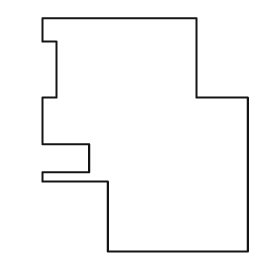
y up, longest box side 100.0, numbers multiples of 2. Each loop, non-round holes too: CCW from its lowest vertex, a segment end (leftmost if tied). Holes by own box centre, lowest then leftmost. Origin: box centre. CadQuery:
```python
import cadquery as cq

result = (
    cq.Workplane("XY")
    .moveTo(-16.0, -50.0)
    .lineTo(44.0, -50.0)
    .lineTo(44.0, 16.0)
    .lineTo(22.0, 16.0)
    .lineTo(22.0, 50.0)
    .lineTo(-44.0, 50.0)
    .lineTo(-44.0, 40.0)
    .lineTo(-38.0, 40.0)
    .lineTo(-38.0, 16.0)
    .lineTo(-44.0, 16.0)
    .lineTo(-44.0, -4.0)
    .lineTo(-24.0, -4.0)
    .lineTo(-24.0, -16.0)
    .lineTo(-44.0, -16.0)
    .lineTo(-44.0, -20.0)
    .lineTo(-16.0, -20.0)
    .close()
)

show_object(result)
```